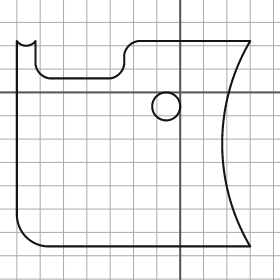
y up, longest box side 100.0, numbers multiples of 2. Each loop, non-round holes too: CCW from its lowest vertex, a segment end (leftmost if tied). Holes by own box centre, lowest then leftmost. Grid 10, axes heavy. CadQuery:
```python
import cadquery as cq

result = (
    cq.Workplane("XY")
    .moveTo(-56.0, -66.0)
    .lineTo(30.0, -66.0)
    .threePointArc((18.0, -22.0), (30.0, 22.0))
    .lineTo(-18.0, 22.0)
    .threePointArc((-22.0, 20.0), (-24.0, 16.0))
    .lineTo(-24.0, 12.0)
    .threePointArc((-26.0, 8.0), (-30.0, 6.0))
    .lineTo(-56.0, 6.0)
    .threePointArc((-60.0, 8.0), (-62.0, 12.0))
    .lineTo(-62.0, 22.0)
    .threePointArc((-66.0, 20.0), (-70.0, 22.0))
    .lineTo(-70.0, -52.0)
    .threePointArc((-66.0, -62.0), (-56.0, -66.0))
    .close()
    .moveTo(-6.0, -6.0)
    .circle(6.0)
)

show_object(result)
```